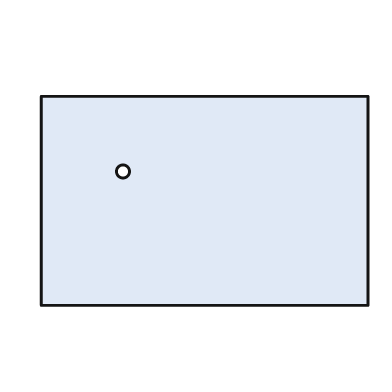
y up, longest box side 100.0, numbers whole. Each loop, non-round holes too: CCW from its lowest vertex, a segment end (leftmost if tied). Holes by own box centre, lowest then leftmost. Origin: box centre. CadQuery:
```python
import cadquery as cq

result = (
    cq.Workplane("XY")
    .moveTo(-50.0, -32.0)
    .lineTo(50.0, -32.0)
    .lineTo(50.0, 32.0)
    .lineTo(-50.0, 32.0)
    .close()
    .moveTo(-25.0, 9.0)
    .circle(2.0)
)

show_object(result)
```